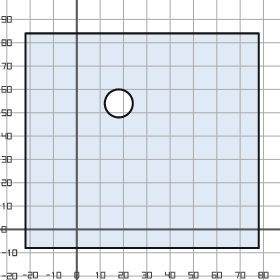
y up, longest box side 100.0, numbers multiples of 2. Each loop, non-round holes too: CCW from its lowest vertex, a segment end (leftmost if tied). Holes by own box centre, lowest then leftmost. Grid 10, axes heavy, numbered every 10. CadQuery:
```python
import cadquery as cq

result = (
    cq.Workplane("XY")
    .moveTo(-22.0, -8.0)
    .lineTo(78.0, -8.0)
    .lineTo(78.0, 84.0)
    .lineTo(-22.0, 84.0)
    .close()
    .moveTo(18.0, 54.0)
    .circle(6.0)
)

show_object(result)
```